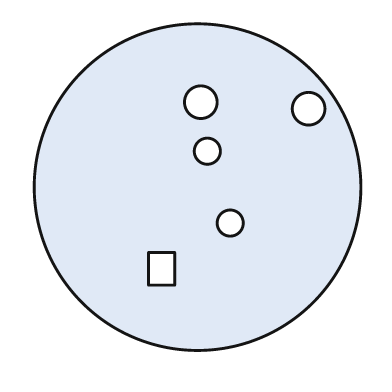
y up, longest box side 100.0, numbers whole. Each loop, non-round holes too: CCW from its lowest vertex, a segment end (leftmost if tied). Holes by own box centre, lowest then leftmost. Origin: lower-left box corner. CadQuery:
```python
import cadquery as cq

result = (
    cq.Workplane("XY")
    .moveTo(50.0, 50.0)
    .circle(50.0)
    .moveTo(35.0, 20.0)
    .lineTo(43.0, 20.0)
    .lineTo(43.0, 30.0)
    .lineTo(35.0, 30.0)
    .close()
    .moveTo(60.0, 39.0)
    .circle(4.0)
    .moveTo(53.0, 61.0)
    .circle(4.0)
    .moveTo(84.0, 74.0)
    .circle(5.0)
    .moveTo(51.0, 76.0)
    .circle(5.0)
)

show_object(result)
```